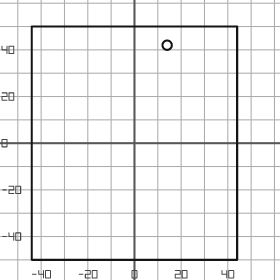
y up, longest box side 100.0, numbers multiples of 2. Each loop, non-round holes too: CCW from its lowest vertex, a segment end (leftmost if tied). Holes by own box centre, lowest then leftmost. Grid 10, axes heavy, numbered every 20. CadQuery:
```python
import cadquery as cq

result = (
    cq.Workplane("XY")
    .moveTo(-44.0, -50.0)
    .lineTo(44.0, -50.0)
    .lineTo(44.0, 50.0)
    .lineTo(-44.0, 50.0)
    .close()
    .moveTo(14.0, 42.0)
    .circle(2.0)
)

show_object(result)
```